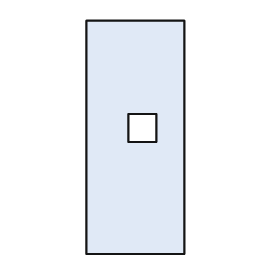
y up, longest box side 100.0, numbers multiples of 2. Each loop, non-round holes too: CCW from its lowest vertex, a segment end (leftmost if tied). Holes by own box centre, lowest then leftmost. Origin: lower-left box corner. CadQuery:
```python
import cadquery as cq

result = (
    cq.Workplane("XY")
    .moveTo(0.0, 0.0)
    .lineTo(42.0, 0.0)
    .lineTo(42.0, 100.0)
    .lineTo(0.0, 100.0)
    .close()
    .moveTo(18.0, 48.0)
    .lineTo(30.0, 48.0)
    .lineTo(30.0, 60.0)
    .lineTo(18.0, 60.0)
    .close()
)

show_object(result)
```